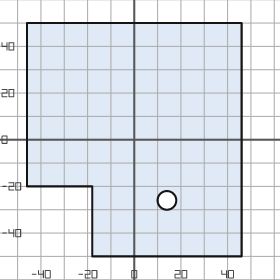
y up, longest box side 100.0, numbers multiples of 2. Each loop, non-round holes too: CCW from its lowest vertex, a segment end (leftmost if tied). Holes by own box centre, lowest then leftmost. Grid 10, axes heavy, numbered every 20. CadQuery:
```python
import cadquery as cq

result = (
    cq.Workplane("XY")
    .moveTo(-18.0, -50.0)
    .lineTo(46.0, -50.0)
    .lineTo(46.0, 50.0)
    .lineTo(-46.0, 50.0)
    .lineTo(-46.0, -20.0)
    .lineTo(-18.0, -20.0)
    .close()
    .moveTo(14.0, -26.0)
    .circle(4.0)
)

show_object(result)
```